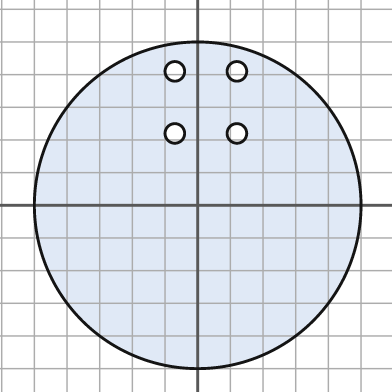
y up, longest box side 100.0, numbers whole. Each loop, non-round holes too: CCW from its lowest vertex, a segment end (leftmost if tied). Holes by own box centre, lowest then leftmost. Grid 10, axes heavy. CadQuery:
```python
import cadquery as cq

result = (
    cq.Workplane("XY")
    .moveTo(0.0, 0.0)
    .circle(50.0)
    .moveTo(-7.0, 22.0)
    .circle(3.0)
    .moveTo(12.0, 22.0)
    .circle(3.0)
    .moveTo(-7.0, 41.0)
    .circle(3.0)
    .moveTo(12.0, 41.0)
    .circle(3.0)
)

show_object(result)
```